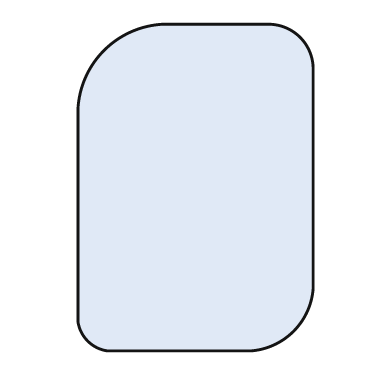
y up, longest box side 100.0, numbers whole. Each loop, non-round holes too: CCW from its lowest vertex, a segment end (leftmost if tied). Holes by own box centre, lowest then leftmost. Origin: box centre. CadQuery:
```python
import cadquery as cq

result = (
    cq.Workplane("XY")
    .moveTo(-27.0, -50.0)
    .lineTo(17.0, -50.0)
    .threePointArc((30.0, -44.0), (36.0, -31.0))
    .lineTo(36.0, 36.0)
    .threePointArc((32.0, 46.0), (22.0, 50.0))
    .lineTo(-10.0, 50.0)
    .threePointArc((-28.0, 42.0), (-36.0, 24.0))
    .lineTo(-36.0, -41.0)
    .threePointArc((-33.0, -47.0), (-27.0, -50.0))
    .close()
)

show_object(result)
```